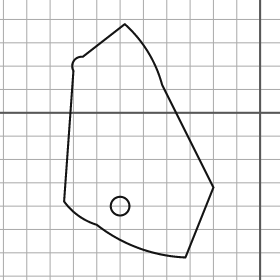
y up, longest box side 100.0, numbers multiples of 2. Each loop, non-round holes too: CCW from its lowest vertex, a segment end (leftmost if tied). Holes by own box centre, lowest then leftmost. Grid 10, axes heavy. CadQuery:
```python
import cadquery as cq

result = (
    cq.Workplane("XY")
    .moveTo(-32.0, -62.0)
    .lineTo(-20.0, -32.0)
    .lineTo(-42.0, 12.0)
    .threePointArc((-48.0, 26.0), (-58.0, 38.0))
    .lineTo(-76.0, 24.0)
    .threePointArc((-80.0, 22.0), (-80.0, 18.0))
    .lineTo(-84.0, -38.0)
    .threePointArc((-78.0, -44.0), (-70.0, -48.0))
    .threePointArc((-52.0, -58.0), (-32.0, -62.0))
    .close()
    .moveTo(-60.0, -40.0)
    .circle(4.0)
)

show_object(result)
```